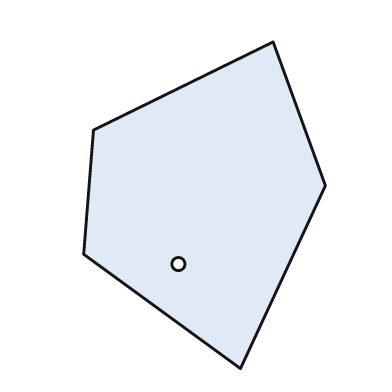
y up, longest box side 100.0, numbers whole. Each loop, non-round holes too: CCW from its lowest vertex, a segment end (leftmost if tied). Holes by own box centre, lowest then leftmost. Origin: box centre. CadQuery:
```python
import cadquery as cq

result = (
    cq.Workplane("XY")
    .moveTo(11.0, -50.0)
    .lineTo(37.0, 6.0)
    .lineTo(21.0, 50.0)
    .lineTo(-34.0, 23.0)
    .lineTo(-37.0, -15.0)
    .close()
    .moveTo(-8.0, -18.0)
    .circle(2.0)
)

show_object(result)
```